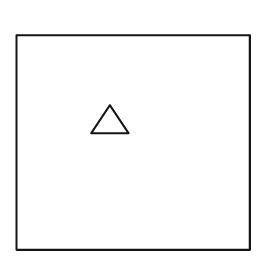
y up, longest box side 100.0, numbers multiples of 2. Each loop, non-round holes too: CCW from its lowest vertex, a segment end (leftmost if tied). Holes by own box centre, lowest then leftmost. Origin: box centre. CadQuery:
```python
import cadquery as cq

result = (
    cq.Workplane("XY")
    .moveTo(-50.0, -46.0)
    .lineTo(50.0, -46.0)
    .lineTo(50.0, 46.0)
    .lineTo(-50.0, 46.0)
    .close()
    .moveTo(-18.0, 4.0)
    .lineTo(-2.0, 4.0)
    .lineTo(-10.0, 16.0)
    .close()
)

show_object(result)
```